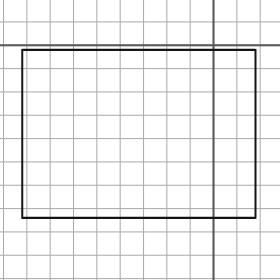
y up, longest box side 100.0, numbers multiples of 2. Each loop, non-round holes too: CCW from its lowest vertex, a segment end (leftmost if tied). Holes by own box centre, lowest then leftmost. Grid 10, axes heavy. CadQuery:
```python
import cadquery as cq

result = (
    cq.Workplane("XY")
    .moveTo(-82.0, -74.0)
    .lineTo(18.0, -74.0)
    .lineTo(18.0, -2.0)
    .lineTo(-82.0, -2.0)
    .close()
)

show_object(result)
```